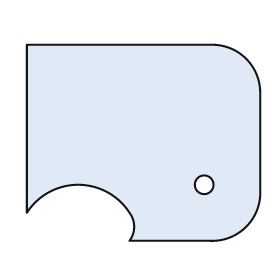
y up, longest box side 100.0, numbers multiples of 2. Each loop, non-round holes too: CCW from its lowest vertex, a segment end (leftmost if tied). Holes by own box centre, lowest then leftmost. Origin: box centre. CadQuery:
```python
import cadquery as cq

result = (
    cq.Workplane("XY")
    .moveTo(-6.0, -42.0)
    .lineTo(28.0, -42.0)
    .threePointArc((44.0, -36.0), (50.0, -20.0))
    .lineTo(50.0, 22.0)
    .threePointArc((44.0, 36.0), (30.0, 42.0))
    .lineTo(-50.0, 42.0)
    .lineTo(-50.0, -30.0)
    .threePointArc((-28.0, -18.0), (-6.0, -30.0))
    .threePointArc((-4.0, -36.0), (-6.0, -42.0))
    .close()
    .moveTo(26.0, -18.0)
    .circle(4.0)
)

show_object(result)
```